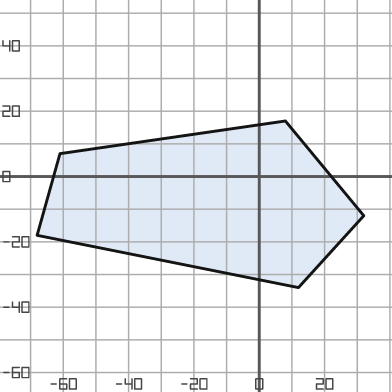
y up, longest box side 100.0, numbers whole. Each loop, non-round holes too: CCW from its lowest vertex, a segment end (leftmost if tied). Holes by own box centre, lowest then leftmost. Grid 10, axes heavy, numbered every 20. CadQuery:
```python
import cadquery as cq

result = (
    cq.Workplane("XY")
    .moveTo(12.0, -34.0)
    .lineTo(32.0, -12.0)
    .lineTo(8.0, 17.0)
    .lineTo(-61.0, 7.0)
    .lineTo(-68.0, -18.0)
    .close()
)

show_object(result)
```